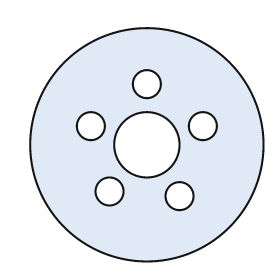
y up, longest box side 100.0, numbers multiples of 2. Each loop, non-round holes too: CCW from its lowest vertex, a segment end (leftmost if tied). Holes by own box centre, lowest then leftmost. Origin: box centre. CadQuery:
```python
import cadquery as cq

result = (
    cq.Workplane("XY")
    .moveTo(0.0, 0.0)
    .circle(50.0)
    .moveTo(14.0, -22.0)
    .circle(6.0)
    .moveTo(-16.0, -20.0)
    .circle(6.0)
    .moveTo(0.0, 0.0)
    .circle(14.0)
    .moveTo(-24.0, 8.0)
    .circle(6.0)
    .moveTo(24.0, 8.0)
    .circle(6.0)
    .moveTo(0.0, 26.0)
    .circle(6.0)
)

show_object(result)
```